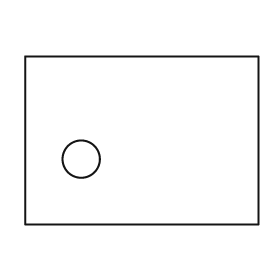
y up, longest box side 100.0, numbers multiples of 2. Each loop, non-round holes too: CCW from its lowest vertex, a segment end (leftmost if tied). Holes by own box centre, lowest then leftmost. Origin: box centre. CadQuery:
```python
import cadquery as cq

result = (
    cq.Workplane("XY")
    .moveTo(-50.0, -36.0)
    .lineTo(50.0, -36.0)
    .lineTo(50.0, 36.0)
    .lineTo(-50.0, 36.0)
    .close()
    .moveTo(-26.0, -8.0)
    .circle(8.0)
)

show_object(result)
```